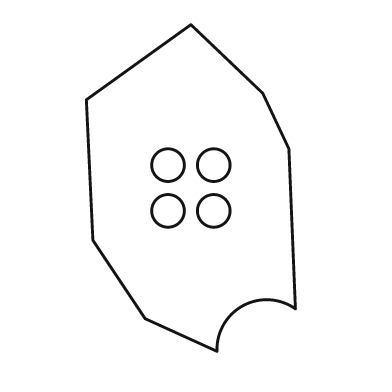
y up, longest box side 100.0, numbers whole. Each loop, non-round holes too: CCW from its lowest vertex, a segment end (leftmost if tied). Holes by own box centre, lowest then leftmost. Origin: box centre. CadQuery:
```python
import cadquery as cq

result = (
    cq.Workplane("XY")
    .moveTo(8.0, -50.0)
    .threePointArc((16.0, -36.0), (32.0, -37.0))
    .lineTo(30.0, 12.0)
    .lineTo(22.0, 29.0)
    .lineTo(0.0, 50.0)
    .lineTo(-32.0, 27.0)
    .lineTo(-30.0, -16.0)
    .lineTo(-14.0, -40.0)
    .close()
    .moveTo(-7.0, -7.0)
    .circle(5.0)
    .moveTo(7.0, -7.0)
    .circle(5.0)
    .moveTo(-7.0, 7.0)
    .circle(5.0)
    .moveTo(7.0, 7.0)
    .circle(5.0)
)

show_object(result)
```